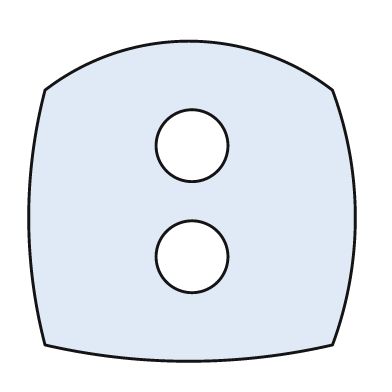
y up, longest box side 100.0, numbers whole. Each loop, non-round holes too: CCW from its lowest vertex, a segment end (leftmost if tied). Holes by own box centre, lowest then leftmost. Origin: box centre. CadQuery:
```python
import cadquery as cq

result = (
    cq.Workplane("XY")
    .moveTo(-45.0, -44.0)
    .threePointArc((-1.0, -49.0), (43.0, -44.0))
    .threePointArc((50.0, -5.0), (43.0, 34.0))
    .threePointArc((-1.0, 49.0), (-45.0, 34.0))
    .threePointArc((-50.0, -5.0), (-45.0, -44.0))
    .close()
    .moveTo(0.0, -17.0)
    .circle(11.0)
    .moveTo(0.0, 17.0)
    .circle(11.0)
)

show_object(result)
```